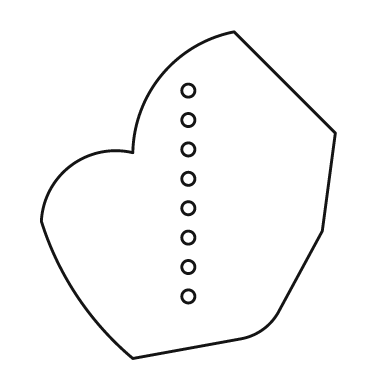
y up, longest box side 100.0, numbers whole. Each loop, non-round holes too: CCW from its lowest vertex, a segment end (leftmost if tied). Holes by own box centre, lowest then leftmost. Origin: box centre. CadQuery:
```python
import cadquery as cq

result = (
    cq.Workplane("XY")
    .moveTo(-17.0, -50.0)
    .lineTo(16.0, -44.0)
    .threePointArc((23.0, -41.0), (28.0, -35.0))
    .lineTo(41.0, -11.0)
    .lineTo(45.0, 19.0)
    .lineTo(14.0, 50.0)
    .threePointArc((-8.0, 37.0), (-17.0, 13.0))
    .threePointArc((-36.0, 9.0), (-45.0, -8.0))
    .threePointArc((-34.0, -31.0), (-17.0, -50.0))
    .close()
    .moveTo(0.0, -31.0)
    .circle(2.0)
    .moveTo(0.0, -22.0)
    .circle(2.0)
    .moveTo(0.0, -13.0)
    .circle(2.0)
    .moveTo(0.0, -4.0)
    .circle(2.0)
    .moveTo(0.0, 5.0)
    .circle(2.0)
    .moveTo(0.0, 14.0)
    .circle(2.0)
    .moveTo(0.0, 23.0)
    .circle(2.0)
    .moveTo(0.0, 32.0)
    .circle(2.0)
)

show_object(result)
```